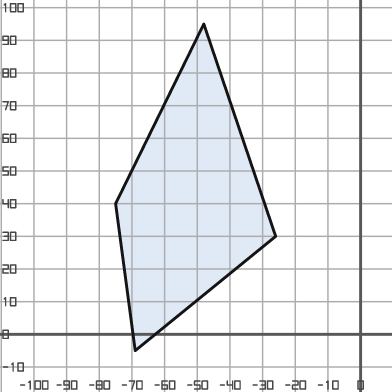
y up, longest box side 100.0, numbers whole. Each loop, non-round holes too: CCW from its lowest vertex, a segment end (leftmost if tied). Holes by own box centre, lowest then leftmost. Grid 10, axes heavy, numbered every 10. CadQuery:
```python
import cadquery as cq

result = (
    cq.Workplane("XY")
    .moveTo(-69.0, -5.0)
    .lineTo(-26.0, 30.0)
    .lineTo(-48.0, 95.0)
    .lineTo(-75.0, 40.0)
    .close()
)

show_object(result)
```